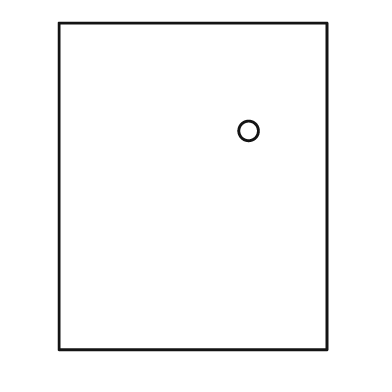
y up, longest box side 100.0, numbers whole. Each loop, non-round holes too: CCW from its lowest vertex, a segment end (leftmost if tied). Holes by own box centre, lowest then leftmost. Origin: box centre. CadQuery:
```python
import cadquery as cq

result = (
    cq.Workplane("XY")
    .moveTo(-41.0, -50.0)
    .lineTo(41.0, -50.0)
    .lineTo(41.0, 50.0)
    .lineTo(-41.0, 50.0)
    .close()
    .moveTo(17.0, 17.0)
    .circle(3.0)
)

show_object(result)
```